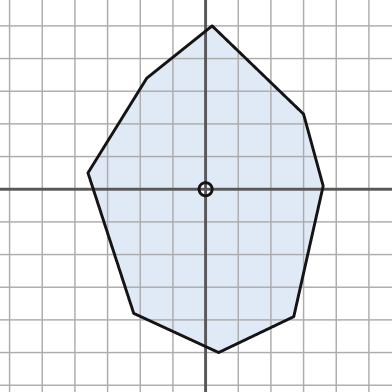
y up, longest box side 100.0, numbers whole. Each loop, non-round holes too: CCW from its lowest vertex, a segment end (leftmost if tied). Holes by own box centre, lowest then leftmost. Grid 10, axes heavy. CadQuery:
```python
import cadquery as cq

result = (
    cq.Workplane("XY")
    .moveTo(4.0, -50.0)
    .lineTo(27.0, -39.0)
    .lineTo(36.0, 1.0)
    .lineTo(30.0, 23.0)
    .lineTo(2.0, 50.0)
    .lineTo(-18.0, 34.0)
    .lineTo(-36.0, 5.0)
    .lineTo(-22.0, -38.0)
    .close()
    .moveTo(0.0, 0.0)
    .circle(2.0)
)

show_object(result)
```